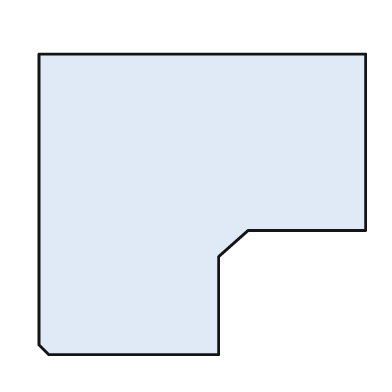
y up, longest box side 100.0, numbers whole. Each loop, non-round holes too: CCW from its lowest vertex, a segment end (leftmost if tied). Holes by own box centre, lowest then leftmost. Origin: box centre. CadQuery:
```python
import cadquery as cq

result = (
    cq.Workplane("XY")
    .moveTo(-47.0, -46.0)
    .lineTo(5.0, -46.0)
    .lineTo(5.0, -16.0)
    .lineTo(14.0, -8.0)
    .lineTo(50.0, -8.0)
    .lineTo(50.0, 46.0)
    .lineTo(-50.0, 46.0)
    .lineTo(-50.0, -43.0)
    .close()
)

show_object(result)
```